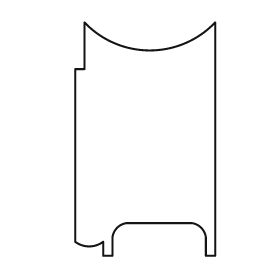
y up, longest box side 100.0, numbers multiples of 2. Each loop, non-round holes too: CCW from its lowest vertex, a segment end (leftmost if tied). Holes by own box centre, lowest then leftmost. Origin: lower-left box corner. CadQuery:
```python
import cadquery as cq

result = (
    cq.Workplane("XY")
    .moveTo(12.0, 0.0)
    .lineTo(16.0, 0.0)
    .lineTo(16.0, 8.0)
    .threePointArc((18.0, 12.0), (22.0, 14.0))
    .lineTo(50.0, 14.0)
    .threePointArc((54.0, 12.0), (56.0, 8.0))
    .lineTo(56.0, 0.0)
    .lineTo(60.0, 0.0)
    .lineTo(60.0, 100.0)
    .threePointArc((32.0, 88.0), (4.0, 100.0))
    .lineTo(4.0, 80.0)
    .lineTo(0.0, 80.0)
    .lineTo(0.0, 6.0)
    .threePointArc((6.0, 4.0), (12.0, 6.0))
    .close()
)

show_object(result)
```